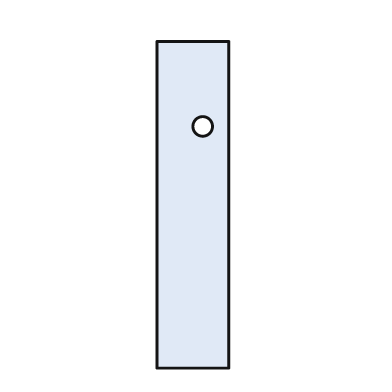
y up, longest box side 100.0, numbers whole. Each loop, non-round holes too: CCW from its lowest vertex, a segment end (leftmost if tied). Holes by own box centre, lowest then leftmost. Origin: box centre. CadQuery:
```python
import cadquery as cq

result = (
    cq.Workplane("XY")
    .moveTo(-11.0, -50.0)
    .lineTo(11.0, -50.0)
    .lineTo(11.0, 50.0)
    .lineTo(-11.0, 50.0)
    .close()
    .moveTo(3.0, 24.0)
    .circle(3.0)
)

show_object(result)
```